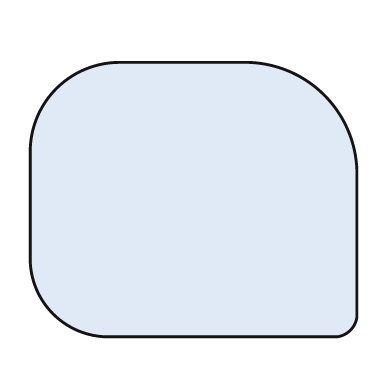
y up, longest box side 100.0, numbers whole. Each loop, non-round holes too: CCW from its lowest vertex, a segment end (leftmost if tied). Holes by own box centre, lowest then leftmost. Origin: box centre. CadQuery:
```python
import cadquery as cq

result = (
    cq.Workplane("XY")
    .moveTo(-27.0, -42.0)
    .lineTo(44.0, -42.0)
    .threePointArc((48.0, -40.0), (50.0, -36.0))
    .lineTo(50.0, 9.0)
    .threePointArc((40.0, 32.0), (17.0, 42.0))
    .lineTo(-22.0, 42.0)
    .threePointArc((-42.0, 34.0), (-50.0, 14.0))
    .lineTo(-50.0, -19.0)
    .threePointArc((-43.0, -35.0), (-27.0, -42.0))
    .close()
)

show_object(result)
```